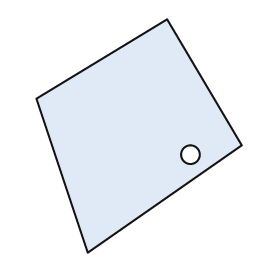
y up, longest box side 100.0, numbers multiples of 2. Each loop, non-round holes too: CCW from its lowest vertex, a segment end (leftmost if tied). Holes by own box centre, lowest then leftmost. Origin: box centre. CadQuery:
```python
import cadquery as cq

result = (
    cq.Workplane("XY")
    .moveTo(-22.0, -50.0)
    .lineTo(44.0, -4.0)
    .lineTo(12.0, 50.0)
    .lineTo(-44.0, 16.0)
    .close()
    .moveTo(22.0, -8.0)
    .circle(4.0)
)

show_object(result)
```